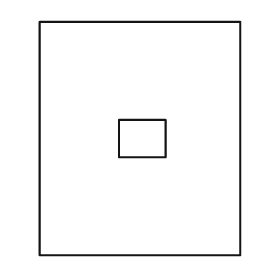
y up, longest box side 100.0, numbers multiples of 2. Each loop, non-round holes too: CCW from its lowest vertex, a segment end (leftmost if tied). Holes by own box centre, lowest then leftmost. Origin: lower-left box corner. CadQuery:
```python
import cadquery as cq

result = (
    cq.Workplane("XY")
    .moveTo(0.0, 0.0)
    .lineTo(86.0, 0.0)
    .lineTo(86.0, 100.0)
    .lineTo(0.0, 100.0)
    .close()
    .moveTo(34.0, 42.0)
    .lineTo(54.0, 42.0)
    .lineTo(54.0, 58.0)
    .lineTo(34.0, 58.0)
    .close()
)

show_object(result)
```